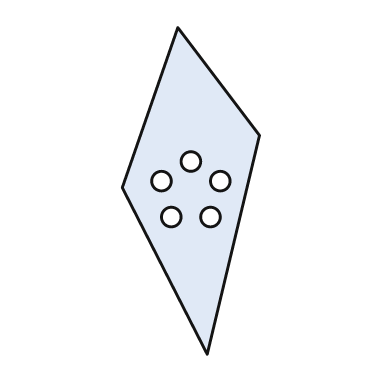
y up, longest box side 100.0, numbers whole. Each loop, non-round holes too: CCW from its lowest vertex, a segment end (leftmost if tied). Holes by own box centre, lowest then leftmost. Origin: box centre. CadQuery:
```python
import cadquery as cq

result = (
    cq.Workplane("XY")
    .moveTo(5.0, -50.0)
    .lineTo(21.0, 17.0)
    .lineTo(-4.0, 50.0)
    .lineTo(-21.0, 1.0)
    .close()
    .moveTo(-6.0, -8.0)
    .circle(3.0)
    .moveTo(6.0, -8.0)
    .circle(3.0)
    .moveTo(-9.0, 3.0)
    .circle(3.0)
    .moveTo(9.0, 3.0)
    .circle(3.0)
    .moveTo(0.0, 9.0)
    .circle(3.0)
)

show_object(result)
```